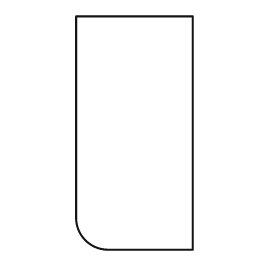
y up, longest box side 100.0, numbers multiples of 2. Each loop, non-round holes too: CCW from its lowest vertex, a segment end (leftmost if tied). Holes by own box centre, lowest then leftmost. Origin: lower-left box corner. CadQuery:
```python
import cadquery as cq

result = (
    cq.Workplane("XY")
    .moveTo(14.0, 0.0)
    .lineTo(50.0, 0.0)
    .lineTo(50.0, 100.0)
    .lineTo(0.0, 100.0)
    .lineTo(0.0, 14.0)
    .threePointArc((4.0, 4.0), (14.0, 0.0))
    .close()
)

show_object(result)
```